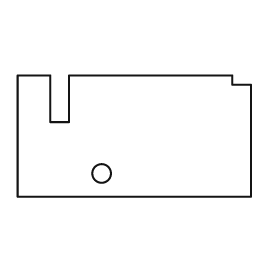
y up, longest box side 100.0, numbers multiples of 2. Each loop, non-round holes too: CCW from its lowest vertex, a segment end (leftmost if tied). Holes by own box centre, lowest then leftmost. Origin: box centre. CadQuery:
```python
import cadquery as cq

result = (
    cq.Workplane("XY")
    .moveTo(-50.0, -26.0)
    .lineTo(50.0, -26.0)
    .lineTo(50.0, 22.0)
    .lineTo(42.0, 22.0)
    .lineTo(42.0, 26.0)
    .lineTo(-28.0, 26.0)
    .lineTo(-28.0, 6.0)
    .lineTo(-36.0, 6.0)
    .lineTo(-36.0, 26.0)
    .lineTo(-50.0, 26.0)
    .close()
    .moveTo(-14.0, -16.0)
    .circle(4.0)
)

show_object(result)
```